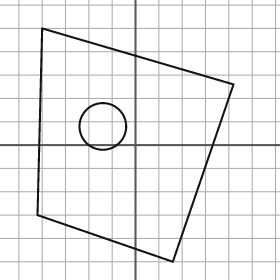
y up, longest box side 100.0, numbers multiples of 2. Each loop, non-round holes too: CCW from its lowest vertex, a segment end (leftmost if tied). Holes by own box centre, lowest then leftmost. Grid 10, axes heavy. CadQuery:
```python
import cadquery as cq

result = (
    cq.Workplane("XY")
    .moveTo(16.0, -50.0)
    .lineTo(42.0, 26.0)
    .lineTo(-40.0, 50.0)
    .lineTo(-42.0, -30.0)
    .close()
    .moveTo(-14.0, 8.0)
    .circle(10.0)
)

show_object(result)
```